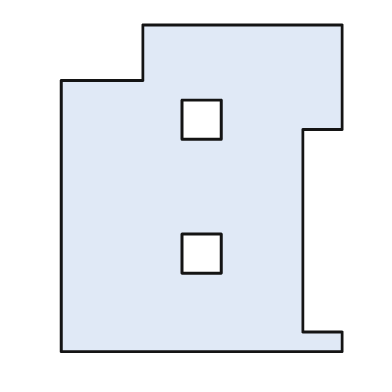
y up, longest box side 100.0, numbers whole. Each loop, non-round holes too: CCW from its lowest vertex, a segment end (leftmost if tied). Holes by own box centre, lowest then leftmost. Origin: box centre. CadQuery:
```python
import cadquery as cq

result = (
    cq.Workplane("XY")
    .moveTo(-43.0, -50.0)
    .lineTo(43.0, -50.0)
    .lineTo(43.0, -44.0)
    .lineTo(31.0, -44.0)
    .lineTo(31.0, 18.0)
    .lineTo(43.0, 18.0)
    .lineTo(43.0, 50.0)
    .lineTo(-18.0, 50.0)
    .lineTo(-18.0, 33.0)
    .lineTo(-43.0, 33.0)
    .close()
    .moveTo(-6.0, -26.0)
    .lineTo(6.0, -26.0)
    .lineTo(6.0, -14.0)
    .lineTo(-6.0, -14.0)
    .close()
    .moveTo(-6.0, 15.0)
    .lineTo(6.0, 15.0)
    .lineTo(6.0, 27.0)
    .lineTo(-6.0, 27.0)
    .close()
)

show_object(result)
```